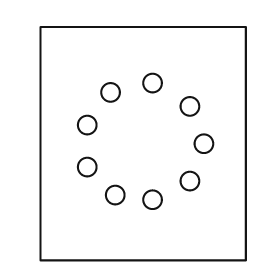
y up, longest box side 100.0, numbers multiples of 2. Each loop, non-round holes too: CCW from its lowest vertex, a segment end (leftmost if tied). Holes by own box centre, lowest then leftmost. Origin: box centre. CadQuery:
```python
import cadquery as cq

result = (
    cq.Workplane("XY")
    .moveTo(-44.0, -50.0)
    .lineTo(44.0, -50.0)
    .lineTo(44.0, 50.0)
    .lineTo(-44.0, 50.0)
    .close()
    .moveTo(4.0, -24.0)
    .circle(4.0)
    .moveTo(-12.0, -22.0)
    .circle(4.0)
    .moveTo(20.0, -16.0)
    .circle(4.0)
    .moveTo(-24.0, -10.0)
    .circle(4.0)
    .moveTo(26.0, 0.0)
    .circle(4.0)
    .moveTo(-24.0, 8.0)
    .circle(4.0)
    .moveTo(20.0, 16.0)
    .circle(4.0)
    .moveTo(-14.0, 22.0)
    .circle(4.0)
    .moveTo(4.0, 26.0)
    .circle(4.0)
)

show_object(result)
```